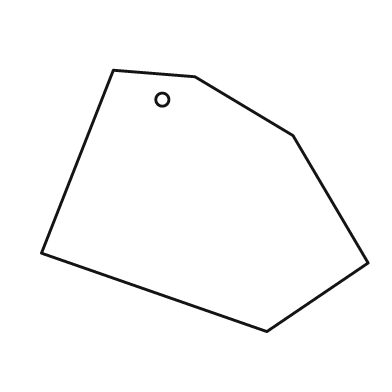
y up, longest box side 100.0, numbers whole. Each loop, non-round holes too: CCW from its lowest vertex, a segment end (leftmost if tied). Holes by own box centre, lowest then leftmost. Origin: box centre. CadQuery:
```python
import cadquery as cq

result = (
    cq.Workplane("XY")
    .moveTo(19.0, -40.0)
    .lineTo(50.0, -19.0)
    .lineTo(27.0, 20.0)
    .lineTo(-3.0, 38.0)
    .lineTo(-28.0, 40.0)
    .lineTo(-50.0, -16.0)
    .close()
    .moveTo(-13.0, 31.0)
    .circle(2.0)
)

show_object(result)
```